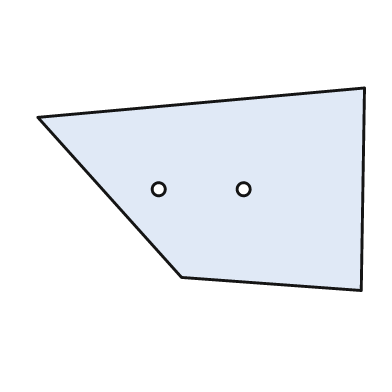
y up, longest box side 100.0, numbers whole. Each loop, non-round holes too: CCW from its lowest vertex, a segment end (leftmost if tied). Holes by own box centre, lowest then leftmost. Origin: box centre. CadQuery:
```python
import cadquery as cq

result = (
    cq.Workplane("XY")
    .moveTo(49.0, -31.0)
    .lineTo(50.0, 31.0)
    .lineTo(-50.0, 22.0)
    .lineTo(-6.0, -27.0)
    .close()
    .moveTo(-13.0, 0.0)
    .circle(2.0)
    .moveTo(13.0, 0.0)
    .circle(2.0)
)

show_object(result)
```